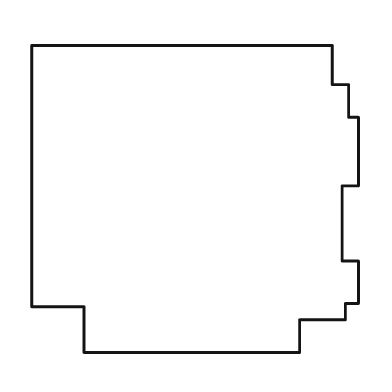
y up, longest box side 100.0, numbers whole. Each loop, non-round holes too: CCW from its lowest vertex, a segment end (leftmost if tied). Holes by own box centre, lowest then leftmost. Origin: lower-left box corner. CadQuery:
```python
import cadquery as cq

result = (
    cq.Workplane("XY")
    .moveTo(16.0, 0.0)
    .lineTo(82.0, 0.0)
    .lineTo(82.0, 10.0)
    .lineTo(96.0, 10.0)
    .lineTo(96.0, 15.0)
    .lineTo(100.0, 15.0)
    .lineTo(100.0, 28.0)
    .lineTo(95.0, 28.0)
    .lineTo(95.0, 51.0)
    .lineTo(100.0, 51.0)
    .lineTo(100.0, 72.0)
    .lineTo(97.0, 72.0)
    .lineTo(97.0, 82.0)
    .lineTo(92.0, 82.0)
    .lineTo(92.0, 94.0)
    .lineTo(0.0, 94.0)
    .lineTo(0.0, 14.0)
    .lineTo(16.0, 14.0)
    .close()
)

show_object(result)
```